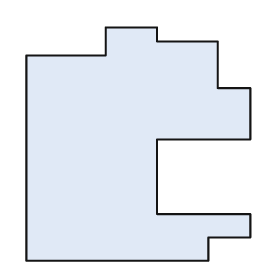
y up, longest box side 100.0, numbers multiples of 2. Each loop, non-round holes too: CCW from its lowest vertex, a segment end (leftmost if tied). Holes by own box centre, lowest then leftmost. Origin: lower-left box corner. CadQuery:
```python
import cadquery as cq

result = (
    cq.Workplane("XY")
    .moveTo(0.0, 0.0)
    .lineTo(78.0, 0.0)
    .lineTo(78.0, 10.0)
    .lineTo(96.0, 10.0)
    .lineTo(96.0, 20.0)
    .lineTo(56.0, 20.0)
    .lineTo(56.0, 52.0)
    .lineTo(96.0, 52.0)
    .lineTo(96.0, 74.0)
    .lineTo(82.0, 74.0)
    .lineTo(82.0, 94.0)
    .lineTo(56.0, 94.0)
    .lineTo(56.0, 100.0)
    .lineTo(34.0, 100.0)
    .lineTo(34.0, 88.0)
    .lineTo(0.0, 88.0)
    .close()
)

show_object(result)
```